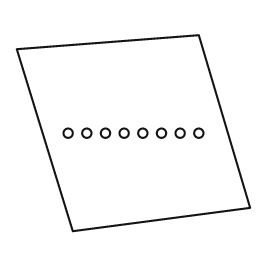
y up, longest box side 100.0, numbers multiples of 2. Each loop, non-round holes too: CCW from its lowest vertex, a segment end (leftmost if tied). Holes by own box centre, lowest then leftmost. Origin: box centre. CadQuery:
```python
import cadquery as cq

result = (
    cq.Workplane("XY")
    .moveTo(-26.0, -42.0)
    .lineTo(50.0, -32.0)
    .lineTo(28.0, 42.0)
    .lineTo(-50.0, 36.0)
    .close()
    .moveTo(-28.0, 0.0)
    .circle(2.0)
    .moveTo(-20.0, 0.0)
    .circle(2.0)
    .moveTo(-12.0, 0.0)
    .circle(2.0)
    .moveTo(-4.0, 0.0)
    .circle(2.0)
    .moveTo(4.0, 0.0)
    .circle(2.0)
    .moveTo(12.0, 0.0)
    .circle(2.0)
    .moveTo(20.0, 0.0)
    .circle(2.0)
    .moveTo(28.0, 0.0)
    .circle(2.0)
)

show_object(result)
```